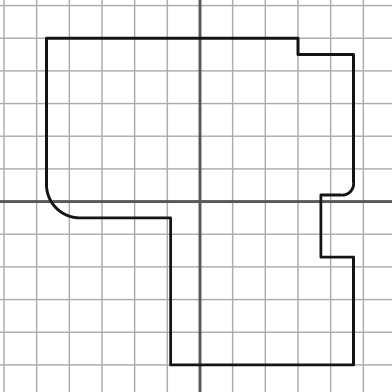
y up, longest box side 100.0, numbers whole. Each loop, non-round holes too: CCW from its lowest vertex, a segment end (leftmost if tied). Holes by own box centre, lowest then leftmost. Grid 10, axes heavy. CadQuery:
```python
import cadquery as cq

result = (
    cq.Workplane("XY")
    .moveTo(-9.0, -50.0)
    .lineTo(47.0, -50.0)
    .lineTo(47.0, -17.0)
    .lineTo(37.0, -17.0)
    .lineTo(37.0, 2.0)
    .lineTo(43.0, 2.0)
    .threePointArc((46.0, 3.0), (47.0, 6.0))
    .lineTo(47.0, 45.0)
    .lineTo(30.0, 45.0)
    .lineTo(30.0, 50.0)
    .lineTo(-47.0, 50.0)
    .lineTo(-47.0, 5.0)
    .threePointArc((-44.0, -2.0), (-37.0, -5.0))
    .lineTo(-9.0, -5.0)
    .close()
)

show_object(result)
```